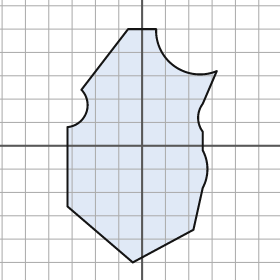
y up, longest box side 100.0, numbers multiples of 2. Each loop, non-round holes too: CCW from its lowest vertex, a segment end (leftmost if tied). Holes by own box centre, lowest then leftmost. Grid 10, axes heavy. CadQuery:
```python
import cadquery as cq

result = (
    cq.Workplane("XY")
    .moveTo(-4.0, -50.0)
    .lineTo(22.0, -36.0)
    .lineTo(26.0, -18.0)
    .threePointArc((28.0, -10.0), (26.0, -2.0))
    .lineTo(26.0, 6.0)
    .threePointArc((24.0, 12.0), (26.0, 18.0))
    .lineTo(32.0, 32.0)
    .threePointArc((14.0, 34.0), (6.0, 50.0))
    .lineTo(-6.0, 50.0)
    .lineTo(-26.0, 24.0)
    .threePointArc((-24.0, 14.0), (-32.0, 8.0))
    .lineTo(-32.0, -26.0)
    .close()
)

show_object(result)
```